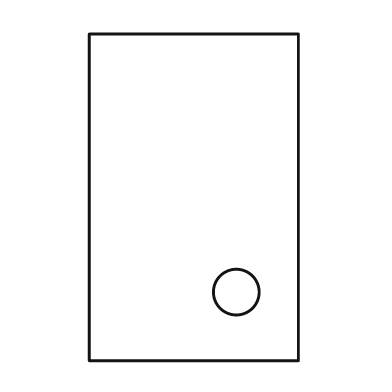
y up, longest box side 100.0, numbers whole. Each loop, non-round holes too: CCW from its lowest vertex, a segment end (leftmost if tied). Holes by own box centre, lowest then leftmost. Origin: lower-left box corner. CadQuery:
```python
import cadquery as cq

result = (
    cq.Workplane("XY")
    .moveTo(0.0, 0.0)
    .lineTo(64.0, 0.0)
    .lineTo(64.0, 100.0)
    .lineTo(0.0, 100.0)
    .close()
    .moveTo(45.0, 21.0)
    .circle(7.0)
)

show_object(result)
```